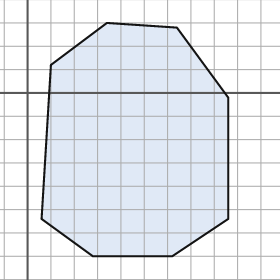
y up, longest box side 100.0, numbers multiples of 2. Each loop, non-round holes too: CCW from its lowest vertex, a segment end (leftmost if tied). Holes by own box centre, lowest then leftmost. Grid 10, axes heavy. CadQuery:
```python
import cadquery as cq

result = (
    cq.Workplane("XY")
    .moveTo(28.0, -70.0)
    .lineTo(62.0, -70.0)
    .lineTo(86.0, -54.0)
    .lineTo(86.0, -2.0)
    .lineTo(64.0, 28.0)
    .lineTo(34.0, 30.0)
    .lineTo(10.0, 12.0)
    .lineTo(6.0, -54.0)
    .close()
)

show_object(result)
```